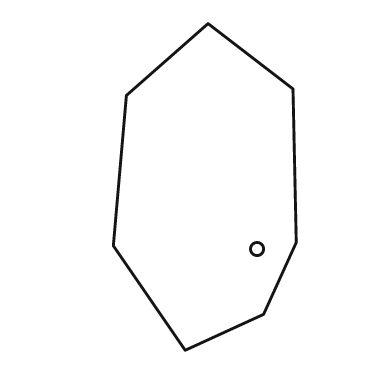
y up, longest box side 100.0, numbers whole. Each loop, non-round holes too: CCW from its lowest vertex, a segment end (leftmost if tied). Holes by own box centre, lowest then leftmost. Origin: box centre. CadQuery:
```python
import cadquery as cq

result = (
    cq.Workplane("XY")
    .moveTo(-6.0, -50.0)
    .lineTo(18.0, -39.0)
    .lineTo(28.0, -17.0)
    .lineTo(27.0, 30.0)
    .lineTo(1.0, 50.0)
    .lineTo(-24.0, 28.0)
    .lineTo(-28.0, -18.0)
    .close()
    .moveTo(16.0, -19.0)
    .circle(2.0)
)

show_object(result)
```